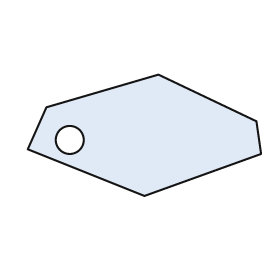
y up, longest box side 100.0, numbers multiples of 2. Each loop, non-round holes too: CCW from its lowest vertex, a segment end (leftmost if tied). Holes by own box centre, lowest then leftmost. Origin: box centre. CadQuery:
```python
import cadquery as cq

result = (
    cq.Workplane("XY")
    .moveTo(0.0, -26.0)
    .lineTo(50.0, -8.0)
    .lineTo(48.0, 6.0)
    .lineTo(6.0, 26.0)
    .lineTo(-42.0, 12.0)
    .lineTo(-50.0, -6.0)
    .close()
    .moveTo(-32.0, -2.0)
    .circle(6.0)
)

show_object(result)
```